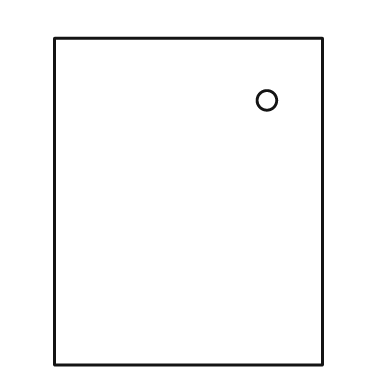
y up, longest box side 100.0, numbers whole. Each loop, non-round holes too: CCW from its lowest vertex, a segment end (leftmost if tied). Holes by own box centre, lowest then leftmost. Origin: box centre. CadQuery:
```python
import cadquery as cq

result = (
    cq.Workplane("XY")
    .moveTo(-41.0, -50.0)
    .lineTo(41.0, -50.0)
    .lineTo(41.0, 50.0)
    .lineTo(-41.0, 50.0)
    .close()
    .moveTo(24.0, 31.0)
    .circle(3.0)
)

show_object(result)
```